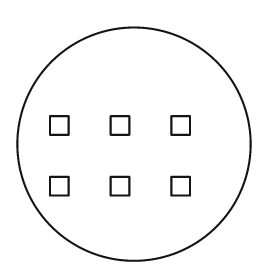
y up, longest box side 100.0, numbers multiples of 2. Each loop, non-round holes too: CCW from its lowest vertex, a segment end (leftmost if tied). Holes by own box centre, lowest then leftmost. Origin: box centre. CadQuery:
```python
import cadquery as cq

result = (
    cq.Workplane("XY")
    .moveTo(0.0, 0.0)
    .circle(50.0)
    .moveTo(-36.0, -22.0)
    .lineTo(-28.0, -22.0)
    .lineTo(-28.0, -14.0)
    .lineTo(-36.0, -14.0)
    .close()
    .moveTo(-10.0, -22.0)
    .lineTo(-2.0, -22.0)
    .lineTo(-2.0, -14.0)
    .lineTo(-10.0, -14.0)
    .close()
    .moveTo(16.0, -22.0)
    .lineTo(24.0, -22.0)
    .lineTo(24.0, -14.0)
    .lineTo(16.0, -14.0)
    .close()
    .moveTo(-36.0, 4.0)
    .lineTo(-28.0, 4.0)
    .lineTo(-28.0, 12.0)
    .lineTo(-36.0, 12.0)
    .close()
    .moveTo(-10.0, 4.0)
    .lineTo(-2.0, 4.0)
    .lineTo(-2.0, 12.0)
    .lineTo(-10.0, 12.0)
    .close()
    .moveTo(16.0, 4.0)
    .lineTo(24.0, 4.0)
    .lineTo(24.0, 12.0)
    .lineTo(16.0, 12.0)
    .close()
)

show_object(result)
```